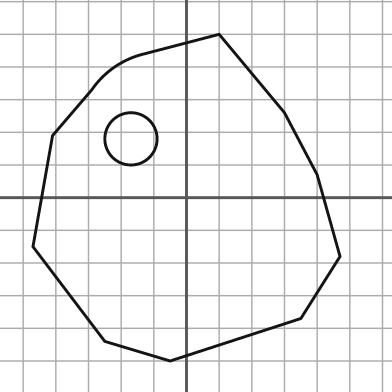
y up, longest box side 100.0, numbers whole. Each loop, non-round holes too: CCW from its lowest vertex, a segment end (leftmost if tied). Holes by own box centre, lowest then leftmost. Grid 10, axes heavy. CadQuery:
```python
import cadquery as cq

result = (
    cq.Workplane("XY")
    .moveTo(-5.0, -50.0)
    .lineTo(35.0, -37.0)
    .lineTo(47.0, -18.0)
    .lineTo(40.0, 7.0)
    .lineTo(30.0, 26.0)
    .lineTo(10.0, 50.0)
    .lineTo(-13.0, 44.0)
    .threePointArc((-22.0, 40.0), (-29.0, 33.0))
    .lineTo(-41.0, 19.0)
    .lineTo(-47.0, -15.0)
    .lineTo(-25.0, -44.0)
    .close()
    .moveTo(-17.0, 18.0)
    .circle(8.0)
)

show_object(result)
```